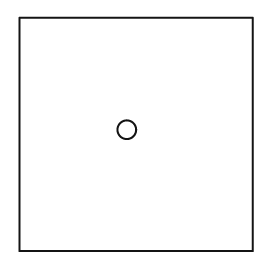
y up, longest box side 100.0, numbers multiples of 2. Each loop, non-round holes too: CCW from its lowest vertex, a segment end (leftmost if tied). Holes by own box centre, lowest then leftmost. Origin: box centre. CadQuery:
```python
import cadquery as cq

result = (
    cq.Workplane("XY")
    .moveTo(-50.0, -50.0)
    .lineTo(50.0, -50.0)
    .lineTo(50.0, 50.0)
    .lineTo(-50.0, 50.0)
    .close()
    .moveTo(-4.0, 2.0)
    .circle(4.0)
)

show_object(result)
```